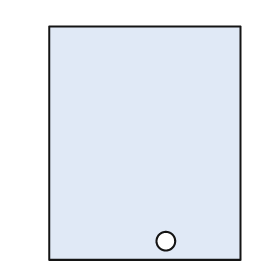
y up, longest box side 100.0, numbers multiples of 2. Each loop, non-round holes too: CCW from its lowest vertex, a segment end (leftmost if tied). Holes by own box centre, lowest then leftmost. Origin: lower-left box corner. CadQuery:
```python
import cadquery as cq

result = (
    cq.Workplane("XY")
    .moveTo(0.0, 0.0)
    .lineTo(82.0, 0.0)
    .lineTo(82.0, 100.0)
    .lineTo(0.0, 100.0)
    .close()
    .moveTo(50.0, 8.0)
    .circle(4.0)
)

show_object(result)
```